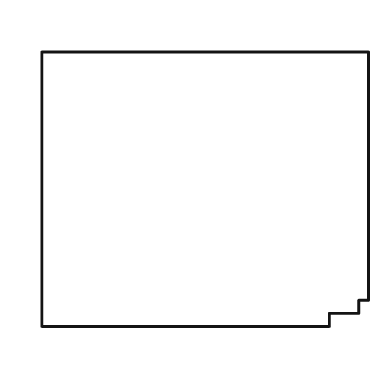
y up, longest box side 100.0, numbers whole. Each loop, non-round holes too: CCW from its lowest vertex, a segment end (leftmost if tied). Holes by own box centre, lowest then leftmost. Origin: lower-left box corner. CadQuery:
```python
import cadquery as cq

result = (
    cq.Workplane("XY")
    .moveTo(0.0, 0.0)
    .lineTo(88.0, 0.0)
    .lineTo(88.0, 4.0)
    .lineTo(97.0, 4.0)
    .lineTo(97.0, 8.0)
    .lineTo(100.0, 8.0)
    .lineTo(100.0, 84.0)
    .lineTo(0.0, 84.0)
    .close()
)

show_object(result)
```